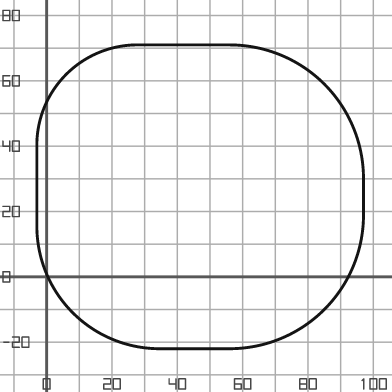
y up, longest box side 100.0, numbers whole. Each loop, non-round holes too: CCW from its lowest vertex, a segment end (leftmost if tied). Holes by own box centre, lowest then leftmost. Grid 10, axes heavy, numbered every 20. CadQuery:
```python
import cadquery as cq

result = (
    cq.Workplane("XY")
    .moveTo(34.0, -22.0)
    .lineTo(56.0, -22.0)
    .threePointArc((85.0, -10.0), (97.0, 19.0))
    .lineTo(97.0, 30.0)
    .threePointArc((85.0, 59.0), (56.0, 71.0))
    .lineTo(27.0, 71.0)
    .threePointArc((6.0, 62.0), (-3.0, 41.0))
    .lineTo(-3.0, 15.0)
    .threePointArc((8.0, -11.0), (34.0, -22.0))
    .close()
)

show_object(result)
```